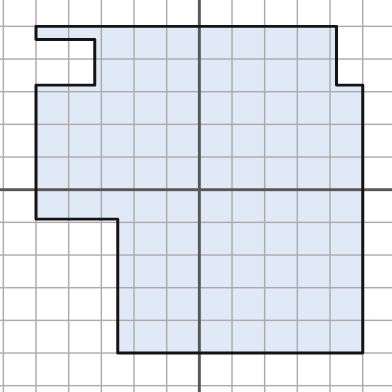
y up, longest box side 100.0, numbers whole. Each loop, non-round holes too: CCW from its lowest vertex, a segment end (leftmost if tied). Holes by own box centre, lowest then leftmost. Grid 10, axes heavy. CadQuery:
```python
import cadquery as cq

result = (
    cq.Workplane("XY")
    .moveTo(-25.0, -50.0)
    .lineTo(50.0, -50.0)
    .lineTo(50.0, 32.0)
    .lineTo(42.0, 32.0)
    .lineTo(42.0, 50.0)
    .lineTo(-50.0, 50.0)
    .lineTo(-50.0, 46.0)
    .lineTo(-32.0, 46.0)
    .lineTo(-32.0, 32.0)
    .lineTo(-50.0, 32.0)
    .lineTo(-50.0, -9.0)
    .lineTo(-25.0, -9.0)
    .close()
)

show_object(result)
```